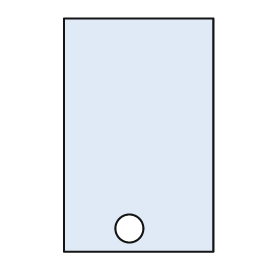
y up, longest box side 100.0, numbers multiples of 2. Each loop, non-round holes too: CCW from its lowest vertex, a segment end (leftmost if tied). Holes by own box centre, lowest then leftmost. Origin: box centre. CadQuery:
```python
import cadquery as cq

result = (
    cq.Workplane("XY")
    .moveTo(-32.0, -50.0)
    .lineTo(32.0, -50.0)
    .lineTo(32.0, 50.0)
    .lineTo(-32.0, 50.0)
    .close()
    .moveTo(-4.0, -40.0)
    .circle(6.0)
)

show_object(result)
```